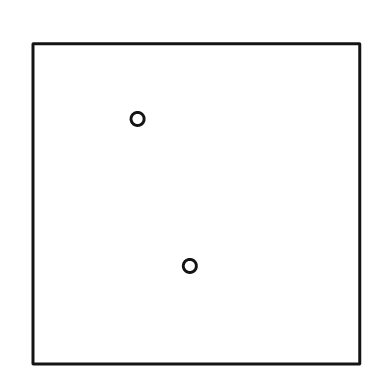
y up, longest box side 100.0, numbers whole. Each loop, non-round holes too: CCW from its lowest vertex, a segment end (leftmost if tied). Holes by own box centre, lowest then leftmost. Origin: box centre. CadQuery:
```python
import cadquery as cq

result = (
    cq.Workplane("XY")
    .moveTo(-50.0, -49.0)
    .lineTo(50.0, -49.0)
    .lineTo(50.0, 49.0)
    .lineTo(-50.0, 49.0)
    .close()
    .moveTo(-2.0, -19.0)
    .circle(2.0)
    .moveTo(-18.0, 26.0)
    .circle(2.0)
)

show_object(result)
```